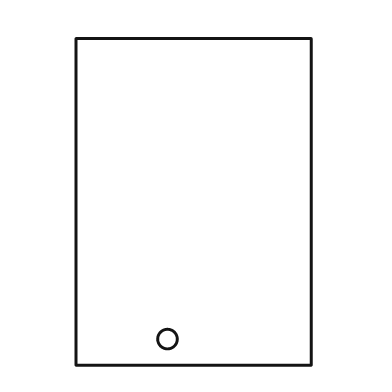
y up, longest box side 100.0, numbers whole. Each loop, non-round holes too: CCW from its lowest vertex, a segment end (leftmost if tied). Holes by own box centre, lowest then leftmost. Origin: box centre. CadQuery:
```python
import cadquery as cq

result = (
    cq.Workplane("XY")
    .moveTo(-36.0, -50.0)
    .lineTo(36.0, -50.0)
    .lineTo(36.0, 50.0)
    .lineTo(-36.0, 50.0)
    .close()
    .moveTo(-8.0, -42.0)
    .circle(3.0)
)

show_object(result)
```